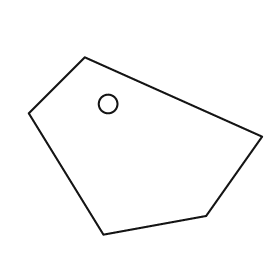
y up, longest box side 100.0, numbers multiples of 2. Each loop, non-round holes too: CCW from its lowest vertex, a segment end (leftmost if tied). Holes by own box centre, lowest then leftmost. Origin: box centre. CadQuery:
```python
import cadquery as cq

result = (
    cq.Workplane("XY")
    .moveTo(-18.0, -38.0)
    .lineTo(26.0, -30.0)
    .lineTo(50.0, 4.0)
    .lineTo(-26.0, 38.0)
    .lineTo(-50.0, 14.0)
    .close()
    .moveTo(-16.0, 18.0)
    .circle(4.0)
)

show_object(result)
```